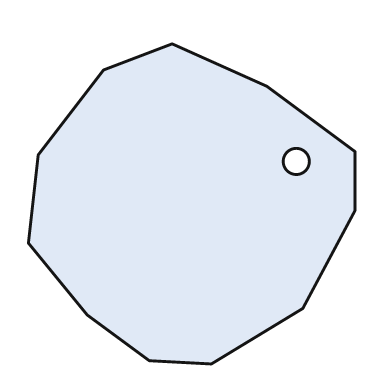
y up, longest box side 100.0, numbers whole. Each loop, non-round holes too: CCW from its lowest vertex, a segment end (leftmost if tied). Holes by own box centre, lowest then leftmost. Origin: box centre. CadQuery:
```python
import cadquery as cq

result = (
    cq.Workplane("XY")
    .moveTo(6.0, -49.0)
    .lineTo(34.0, -32.0)
    .lineTo(50.0, -2.0)
    .lineTo(50.0, 16.0)
    .lineTo(23.0, 36.0)
    .lineTo(-6.0, 49.0)
    .lineTo(-27.0, 41.0)
    .lineTo(-47.0, 15.0)
    .lineTo(-50.0, -12.0)
    .lineTo(-32.0, -34.0)
    .lineTo(-13.0, -48.0)
    .close()
    .moveTo(32.0, 13.0)
    .circle(4.0)
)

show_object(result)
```